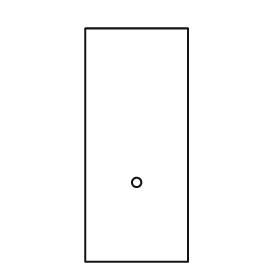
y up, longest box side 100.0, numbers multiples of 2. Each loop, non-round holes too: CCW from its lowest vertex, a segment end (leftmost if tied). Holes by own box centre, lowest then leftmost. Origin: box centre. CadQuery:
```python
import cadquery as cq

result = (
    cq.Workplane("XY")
    .moveTo(-22.0, -50.0)
    .lineTo(22.0, -50.0)
    .lineTo(22.0, 50.0)
    .lineTo(-22.0, 50.0)
    .close()
    .moveTo(0.0, -16.0)
    .circle(2.0)
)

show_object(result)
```